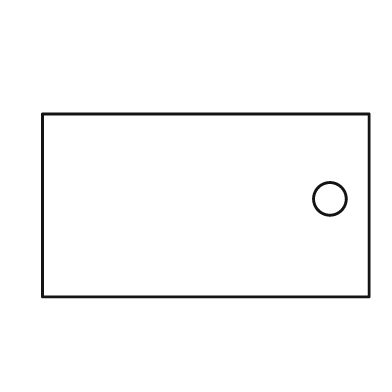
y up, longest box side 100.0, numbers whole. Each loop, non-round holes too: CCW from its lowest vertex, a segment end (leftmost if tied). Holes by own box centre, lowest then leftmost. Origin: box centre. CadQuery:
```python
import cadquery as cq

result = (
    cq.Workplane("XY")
    .moveTo(-50.0, -28.0)
    .lineTo(50.0, -28.0)
    .lineTo(50.0, 28.0)
    .lineTo(-50.0, 28.0)
    .close()
    .moveTo(38.0, 2.0)
    .circle(5.0)
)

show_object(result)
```